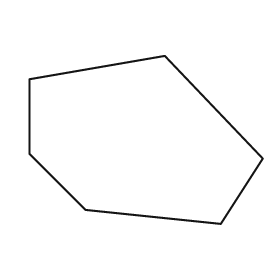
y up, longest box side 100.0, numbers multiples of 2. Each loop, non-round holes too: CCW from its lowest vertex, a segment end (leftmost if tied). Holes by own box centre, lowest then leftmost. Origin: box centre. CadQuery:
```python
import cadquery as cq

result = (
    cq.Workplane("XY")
    .moveTo(32.0, -36.0)
    .lineTo(50.0, -8.0)
    .lineTo(8.0, 36.0)
    .lineTo(-50.0, 26.0)
    .lineTo(-50.0, -6.0)
    .lineTo(-26.0, -30.0)
    .close()
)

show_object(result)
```